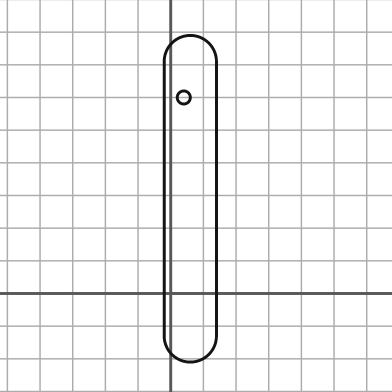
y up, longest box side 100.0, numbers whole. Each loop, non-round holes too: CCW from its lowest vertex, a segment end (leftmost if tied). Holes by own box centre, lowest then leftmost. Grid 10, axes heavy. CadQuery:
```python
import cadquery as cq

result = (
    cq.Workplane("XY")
    .moveTo(-2.0, -13.0)
    .threePointArc((6.0, -21.0), (14.0, -13.0))
    .lineTo(14.0, 71.0)
    .threePointArc((6.0, 79.0), (-2.0, 71.0))
    .close()
    .moveTo(4.0, 60.0)
    .circle(2.0)
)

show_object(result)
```